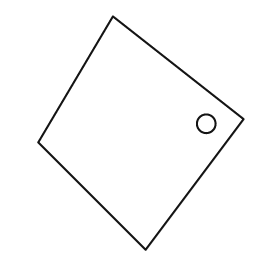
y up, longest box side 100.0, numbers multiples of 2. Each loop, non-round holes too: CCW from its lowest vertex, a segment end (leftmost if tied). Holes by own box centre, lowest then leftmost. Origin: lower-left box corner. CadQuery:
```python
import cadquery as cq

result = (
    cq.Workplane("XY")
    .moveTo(46.0, 0.0)
    .lineTo(88.0, 56.0)
    .lineTo(32.0, 100.0)
    .lineTo(0.0, 46.0)
    .close()
    .moveTo(72.0, 54.0)
    .circle(4.0)
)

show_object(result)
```